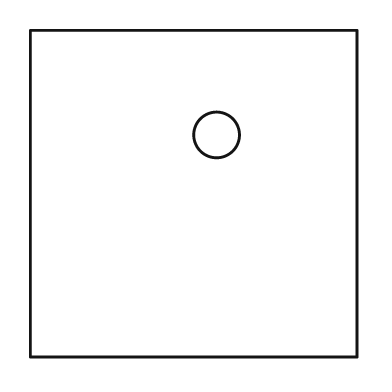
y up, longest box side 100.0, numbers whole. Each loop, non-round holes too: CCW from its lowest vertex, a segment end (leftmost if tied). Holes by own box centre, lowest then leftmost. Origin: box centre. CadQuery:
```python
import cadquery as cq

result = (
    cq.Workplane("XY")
    .moveTo(-50.0, -50.0)
    .lineTo(50.0, -50.0)
    .lineTo(50.0, 50.0)
    .lineTo(-50.0, 50.0)
    .close()
    .moveTo(7.0, 18.0)
    .circle(7.0)
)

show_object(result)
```